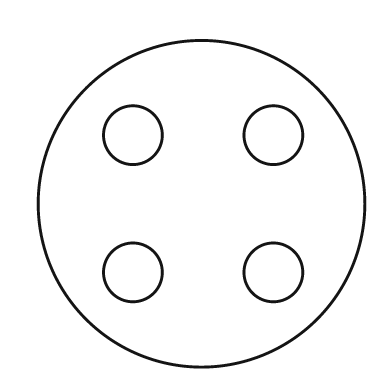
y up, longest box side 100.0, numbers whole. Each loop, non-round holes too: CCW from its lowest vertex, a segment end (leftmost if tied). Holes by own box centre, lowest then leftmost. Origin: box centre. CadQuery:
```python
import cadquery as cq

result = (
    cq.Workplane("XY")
    .moveTo(0.0, 0.0)
    .circle(50.0)
    .moveTo(-21.0, -21.0)
    .circle(9.0)
    .moveTo(22.0, -21.0)
    .circle(9.0)
    .moveTo(-21.0, 21.0)
    .circle(9.0)
    .moveTo(22.0, 21.0)
    .circle(9.0)
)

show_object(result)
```